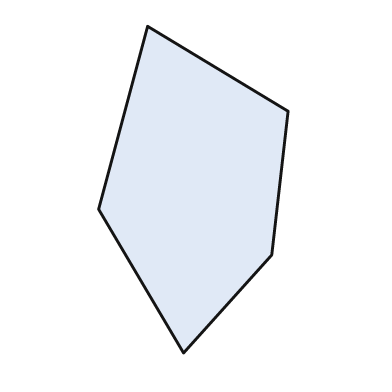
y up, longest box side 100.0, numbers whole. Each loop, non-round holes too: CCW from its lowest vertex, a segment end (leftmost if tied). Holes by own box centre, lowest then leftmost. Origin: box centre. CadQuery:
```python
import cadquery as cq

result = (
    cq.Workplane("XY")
    .moveTo(-3.0, -50.0)
    .lineTo(24.0, -20.0)
    .lineTo(29.0, 24.0)
    .lineTo(-14.0, 50.0)
    .lineTo(-29.0, -6.0)
    .close()
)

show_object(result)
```